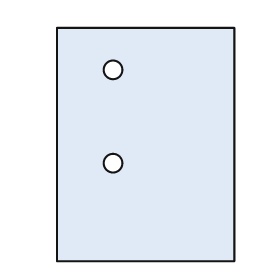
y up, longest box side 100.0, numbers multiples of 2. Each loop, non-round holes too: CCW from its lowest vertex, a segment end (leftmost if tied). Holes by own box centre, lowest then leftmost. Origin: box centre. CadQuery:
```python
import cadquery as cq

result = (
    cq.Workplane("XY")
    .moveTo(-38.0, -50.0)
    .lineTo(38.0, -50.0)
    .lineTo(38.0, 50.0)
    .lineTo(-38.0, 50.0)
    .close()
    .moveTo(-14.0, -8.0)
    .circle(4.0)
    .moveTo(-14.0, 32.0)
    .circle(4.0)
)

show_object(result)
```